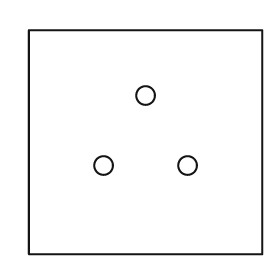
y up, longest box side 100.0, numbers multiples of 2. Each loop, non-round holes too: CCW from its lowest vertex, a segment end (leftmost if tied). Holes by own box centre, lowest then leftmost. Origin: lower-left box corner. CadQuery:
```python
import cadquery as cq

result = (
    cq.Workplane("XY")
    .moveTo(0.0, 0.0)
    .lineTo(100.0, 0.0)
    .lineTo(100.0, 96.0)
    .lineTo(0.0, 96.0)
    .close()
    .moveTo(32.0, 38.0)
    .circle(4.0)
    .moveTo(68.0, 38.0)
    .circle(4.0)
    .moveTo(50.0, 68.0)
    .circle(4.0)
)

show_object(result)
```